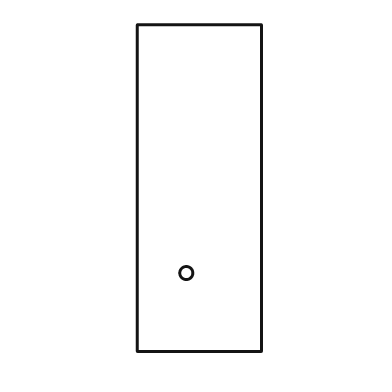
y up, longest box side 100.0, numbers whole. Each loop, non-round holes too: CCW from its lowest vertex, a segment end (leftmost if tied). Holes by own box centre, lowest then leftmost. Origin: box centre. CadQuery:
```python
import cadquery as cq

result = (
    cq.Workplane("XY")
    .moveTo(-19.0, -50.0)
    .lineTo(19.0, -50.0)
    .lineTo(19.0, 50.0)
    .lineTo(-19.0, 50.0)
    .close()
    .moveTo(-4.0, -26.0)
    .circle(2.0)
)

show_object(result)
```